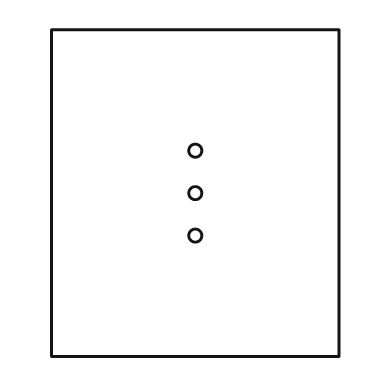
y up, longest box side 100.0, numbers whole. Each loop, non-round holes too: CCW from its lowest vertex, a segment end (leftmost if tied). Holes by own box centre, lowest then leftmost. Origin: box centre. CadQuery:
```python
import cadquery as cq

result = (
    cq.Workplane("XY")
    .moveTo(-44.0, -50.0)
    .lineTo(44.0, -50.0)
    .lineTo(44.0, 50.0)
    .lineTo(-44.0, 50.0)
    .close()
    .moveTo(0.0, -13.0)
    .circle(2.0)
    .moveTo(0.0, 0.0)
    .circle(2.0)
    .moveTo(0.0, 13.0)
    .circle(2.0)
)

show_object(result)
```